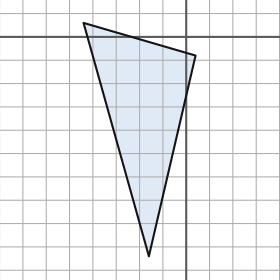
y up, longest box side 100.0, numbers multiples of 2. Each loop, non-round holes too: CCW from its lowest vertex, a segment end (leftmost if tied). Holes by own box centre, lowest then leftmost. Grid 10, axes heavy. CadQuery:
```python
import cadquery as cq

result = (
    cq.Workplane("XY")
    .moveTo(-16.0, -94.0)
    .lineTo(4.0, -8.0)
    .lineTo(-44.0, 6.0)
    .close()
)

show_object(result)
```